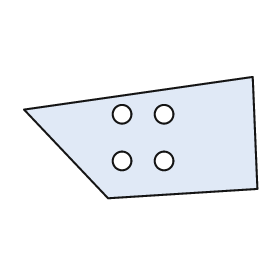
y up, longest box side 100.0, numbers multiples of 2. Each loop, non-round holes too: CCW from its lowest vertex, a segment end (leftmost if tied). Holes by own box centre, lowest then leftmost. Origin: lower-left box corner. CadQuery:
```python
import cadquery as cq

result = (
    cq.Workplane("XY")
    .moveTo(36.0, 0.0)
    .lineTo(100.0, 4.0)
    .lineTo(98.0, 52.0)
    .lineTo(0.0, 38.0)
    .close()
    .moveTo(42.0, 16.0)
    .circle(4.0)
    .moveTo(60.0, 16.0)
    .circle(4.0)
    .moveTo(42.0, 36.0)
    .circle(4.0)
    .moveTo(60.0, 36.0)
    .circle(4.0)
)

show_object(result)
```